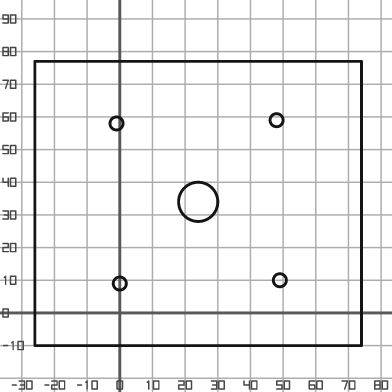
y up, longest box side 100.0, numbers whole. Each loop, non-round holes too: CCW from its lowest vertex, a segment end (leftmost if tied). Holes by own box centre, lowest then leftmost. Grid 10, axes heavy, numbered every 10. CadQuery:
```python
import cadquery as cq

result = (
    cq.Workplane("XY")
    .moveTo(-26.0, -10.0)
    .lineTo(74.0, -10.0)
    .lineTo(74.0, 77.0)
    .lineTo(-26.0, 77.0)
    .close()
    .moveTo(0.0, 9.0)
    .circle(2.0)
    .moveTo(49.0, 10.0)
    .circle(2.0)
    .moveTo(24.0, 34.0)
    .circle(6.0)
    .moveTo(-1.0, 58.0)
    .circle(2.0)
    .moveTo(48.0, 59.0)
    .circle(2.0)
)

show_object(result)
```